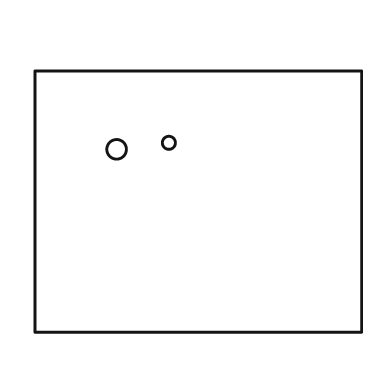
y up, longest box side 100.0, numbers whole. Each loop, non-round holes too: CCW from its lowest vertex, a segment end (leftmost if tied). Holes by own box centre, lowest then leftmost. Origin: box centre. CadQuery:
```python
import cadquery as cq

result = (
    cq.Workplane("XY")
    .moveTo(-50.0, -40.0)
    .lineTo(50.0, -40.0)
    .lineTo(50.0, 40.0)
    .lineTo(-50.0, 40.0)
    .close()
    .moveTo(-25.0, 16.0)
    .circle(3.0)
    .moveTo(-9.0, 18.0)
    .circle(2.0)
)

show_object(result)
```